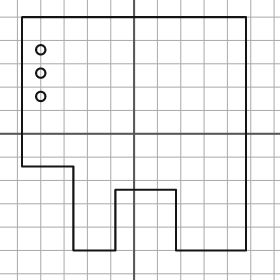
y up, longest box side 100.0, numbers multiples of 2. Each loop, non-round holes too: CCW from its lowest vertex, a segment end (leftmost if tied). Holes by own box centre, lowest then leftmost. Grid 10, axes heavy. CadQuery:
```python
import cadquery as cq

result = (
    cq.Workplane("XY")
    .moveTo(-26.0, -50.0)
    .lineTo(-8.0, -50.0)
    .lineTo(-8.0, -24.0)
    .lineTo(18.0, -24.0)
    .lineTo(18.0, -50.0)
    .lineTo(48.0, -50.0)
    .lineTo(48.0, 50.0)
    .lineTo(-48.0, 50.0)
    .lineTo(-48.0, -14.0)
    .lineTo(-26.0, -14.0)
    .close()
    .moveTo(-40.0, 16.0)
    .circle(2.0)
    .moveTo(-40.0, 26.0)
    .circle(2.0)
    .moveTo(-40.0, 36.0)
    .circle(2.0)
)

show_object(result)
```